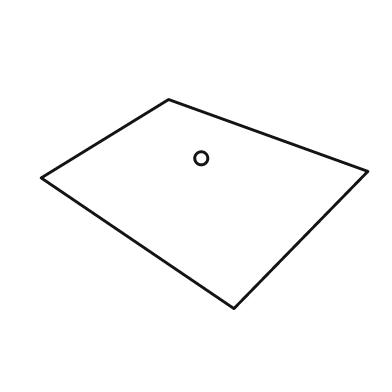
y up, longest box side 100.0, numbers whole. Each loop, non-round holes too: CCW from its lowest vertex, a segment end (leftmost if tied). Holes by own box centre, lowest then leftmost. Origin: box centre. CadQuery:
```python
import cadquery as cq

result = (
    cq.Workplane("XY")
    .moveTo(9.0, -32.0)
    .lineTo(50.0, 10.0)
    .lineTo(-11.0, 32.0)
    .lineTo(-50.0, 8.0)
    .close()
    .moveTo(-1.0, 14.0)
    .circle(2.0)
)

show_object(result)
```